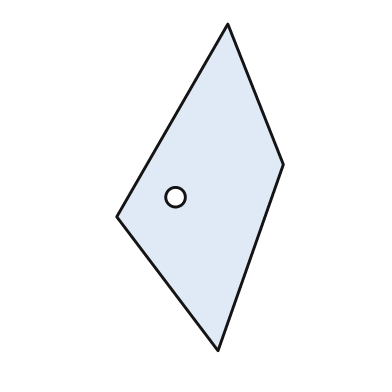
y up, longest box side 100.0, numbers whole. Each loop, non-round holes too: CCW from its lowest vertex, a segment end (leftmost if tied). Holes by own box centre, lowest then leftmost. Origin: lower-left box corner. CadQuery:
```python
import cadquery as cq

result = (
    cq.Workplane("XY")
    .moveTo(31.0, 0.0)
    .lineTo(51.0, 57.0)
    .lineTo(34.0, 100.0)
    .lineTo(0.0, 41.0)
    .close()
    .moveTo(18.0, 47.0)
    .circle(3.0)
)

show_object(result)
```